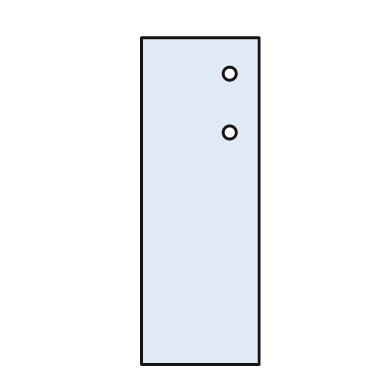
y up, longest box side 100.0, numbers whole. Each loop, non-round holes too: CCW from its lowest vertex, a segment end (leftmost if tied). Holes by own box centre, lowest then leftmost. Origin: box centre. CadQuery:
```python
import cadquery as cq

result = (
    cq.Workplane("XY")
    .moveTo(-18.0, -50.0)
    .lineTo(18.0, -50.0)
    .lineTo(18.0, 50.0)
    .lineTo(-18.0, 50.0)
    .close()
    .moveTo(9.0, 21.0)
    .circle(2.0)
    .moveTo(9.0, 39.0)
    .circle(2.0)
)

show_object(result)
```